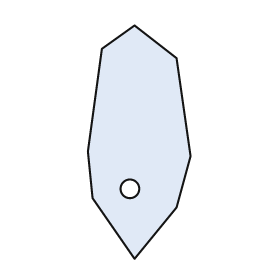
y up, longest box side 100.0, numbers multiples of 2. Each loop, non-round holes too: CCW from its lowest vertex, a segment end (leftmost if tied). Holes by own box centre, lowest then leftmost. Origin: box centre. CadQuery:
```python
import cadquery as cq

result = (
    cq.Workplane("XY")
    .moveTo(-2.0, -50.0)
    .lineTo(16.0, -28.0)
    .lineTo(22.0, -6.0)
    .lineTo(16.0, 36.0)
    .lineTo(-2.0, 50.0)
    .lineTo(-16.0, 40.0)
    .lineTo(-22.0, -4.0)
    .lineTo(-20.0, -24.0)
    .close()
    .moveTo(-4.0, -20.0)
    .circle(4.0)
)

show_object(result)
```